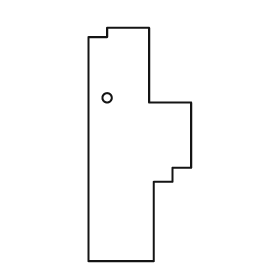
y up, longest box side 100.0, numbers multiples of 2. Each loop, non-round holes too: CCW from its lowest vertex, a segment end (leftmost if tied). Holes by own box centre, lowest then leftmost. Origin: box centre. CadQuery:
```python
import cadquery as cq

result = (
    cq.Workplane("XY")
    .moveTo(-22.0, -50.0)
    .lineTo(6.0, -50.0)
    .lineTo(6.0, -16.0)
    .lineTo(14.0, -16.0)
    .lineTo(14.0, -10.0)
    .lineTo(22.0, -10.0)
    .lineTo(22.0, 18.0)
    .lineTo(4.0, 18.0)
    .lineTo(4.0, 50.0)
    .lineTo(-14.0, 50.0)
    .lineTo(-14.0, 46.0)
    .lineTo(-22.0, 46.0)
    .close()
    .moveTo(-14.0, 20.0)
    .circle(2.0)
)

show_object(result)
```